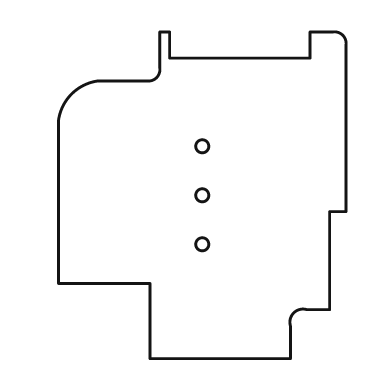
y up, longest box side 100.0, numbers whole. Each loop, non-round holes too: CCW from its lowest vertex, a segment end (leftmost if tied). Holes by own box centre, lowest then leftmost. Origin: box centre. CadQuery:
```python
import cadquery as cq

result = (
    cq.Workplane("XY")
    .moveTo(-16.0, -50.0)
    .lineTo(27.0, -50.0)
    .lineTo(27.0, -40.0)
    .threePointArc((28.0, -36.0), (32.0, -35.0))
    .lineTo(39.0, -35.0)
    .lineTo(39.0, -5.0)
    .lineTo(44.0, -5.0)
    .lineTo(44.0, 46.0)
    .threePointArc((43.0, 49.0), (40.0, 50.0))
    .lineTo(33.0, 50.0)
    .lineTo(33.0, 42.0)
    .lineTo(-10.0, 42.0)
    .lineTo(-10.0, 50.0)
    .lineTo(-13.0, 50.0)
    .lineTo(-13.0, 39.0)
    .threePointArc((-14.0, 36.0), (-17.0, 35.0))
    .lineTo(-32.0, 35.0)
    .threePointArc((-40.0, 31.0), (-44.0, 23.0))
    .lineTo(-44.0, -27.0)
    .lineTo(-16.0, -27.0)
    .close()
    .moveTo(0.0, -15.0)
    .circle(2.0)
    .moveTo(0.0, 0.0)
    .circle(2.0)
    .moveTo(0.0, 15.0)
    .circle(2.0)
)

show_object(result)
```